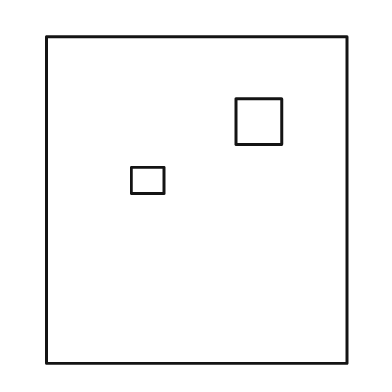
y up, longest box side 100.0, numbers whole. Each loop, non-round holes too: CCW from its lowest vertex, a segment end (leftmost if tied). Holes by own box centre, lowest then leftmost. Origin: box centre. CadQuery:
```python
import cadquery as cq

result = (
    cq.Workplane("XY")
    .moveTo(-46.0, -50.0)
    .lineTo(46.0, -50.0)
    .lineTo(46.0, 50.0)
    .lineTo(-46.0, 50.0)
    .close()
    .moveTo(-20.0, 2.0)
    .lineTo(-10.0, 2.0)
    .lineTo(-10.0, 10.0)
    .lineTo(-20.0, 10.0)
    .close()
    .moveTo(12.0, 17.0)
    .lineTo(26.0, 17.0)
    .lineTo(26.0, 31.0)
    .lineTo(12.0, 31.0)
    .close()
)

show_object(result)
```